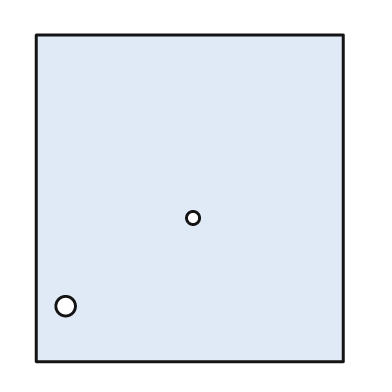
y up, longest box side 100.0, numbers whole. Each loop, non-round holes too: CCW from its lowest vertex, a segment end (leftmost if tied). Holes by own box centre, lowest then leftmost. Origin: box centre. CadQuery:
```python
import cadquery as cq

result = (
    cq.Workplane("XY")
    .moveTo(-47.0, -50.0)
    .lineTo(47.0, -50.0)
    .lineTo(47.0, 50.0)
    .lineTo(-47.0, 50.0)
    .close()
    .moveTo(-38.0, -33.0)
    .circle(3.0)
    .moveTo(1.0, -6.0)
    .circle(2.0)
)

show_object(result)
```